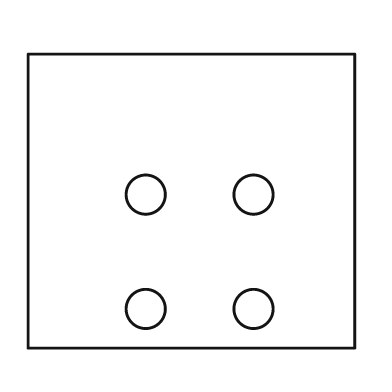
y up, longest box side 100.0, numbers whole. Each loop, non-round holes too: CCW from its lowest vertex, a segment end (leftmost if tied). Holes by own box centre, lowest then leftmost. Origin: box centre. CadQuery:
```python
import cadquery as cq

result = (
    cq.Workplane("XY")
    .moveTo(-50.0, -45.0)
    .lineTo(50.0, -45.0)
    .lineTo(50.0, 45.0)
    .lineTo(-50.0, 45.0)
    .close()
    .moveTo(-14.0, -33.0)
    .circle(6.0)
    .moveTo(19.0, -33.0)
    .circle(6.0)
    .moveTo(-14.0, 2.0)
    .circle(6.0)
    .moveTo(19.0, 2.0)
    .circle(6.0)
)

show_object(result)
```